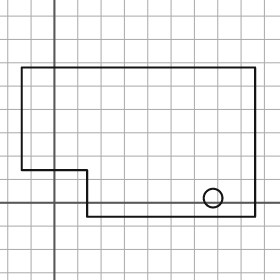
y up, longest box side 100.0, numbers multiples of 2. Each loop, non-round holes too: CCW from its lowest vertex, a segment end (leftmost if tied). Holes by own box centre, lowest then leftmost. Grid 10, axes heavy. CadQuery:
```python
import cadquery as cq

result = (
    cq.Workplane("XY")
    .moveTo(14.0, -6.0)
    .lineTo(86.0, -6.0)
    .lineTo(86.0, 58.0)
    .lineTo(-14.0, 58.0)
    .lineTo(-14.0, 14.0)
    .lineTo(14.0, 14.0)
    .close()
    .moveTo(68.0, 2.0)
    .circle(4.0)
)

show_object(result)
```